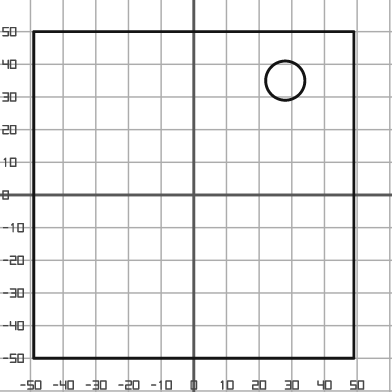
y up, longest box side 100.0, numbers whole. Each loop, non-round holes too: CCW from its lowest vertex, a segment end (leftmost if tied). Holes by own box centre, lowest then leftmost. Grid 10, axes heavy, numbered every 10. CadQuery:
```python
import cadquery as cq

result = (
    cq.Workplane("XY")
    .moveTo(-49.0, -50.0)
    .lineTo(49.0, -50.0)
    .lineTo(49.0, 50.0)
    .lineTo(-49.0, 50.0)
    .close()
    .moveTo(28.0, 35.0)
    .circle(6.0)
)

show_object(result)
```